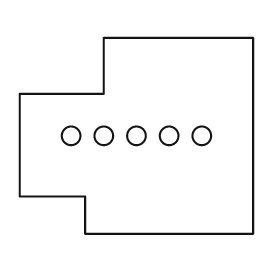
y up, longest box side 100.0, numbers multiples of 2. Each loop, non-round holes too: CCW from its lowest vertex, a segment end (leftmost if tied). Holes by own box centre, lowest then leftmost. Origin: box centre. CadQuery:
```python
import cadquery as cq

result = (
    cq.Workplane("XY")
    .moveTo(-22.0, -42.0)
    .lineTo(50.0, -42.0)
    .lineTo(50.0, 42.0)
    .lineTo(-14.0, 42.0)
    .lineTo(-14.0, 18.0)
    .lineTo(-50.0, 18.0)
    .lineTo(-50.0, -26.0)
    .lineTo(-22.0, -26.0)
    .close()
    .moveTo(-28.0, 0.0)
    .circle(4.0)
    .moveTo(-14.0, 0.0)
    .circle(4.0)
    .moveTo(0.0, 0.0)
    .circle(4.0)
    .moveTo(14.0, 0.0)
    .circle(4.0)
    .moveTo(28.0, 0.0)
    .circle(4.0)
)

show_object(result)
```